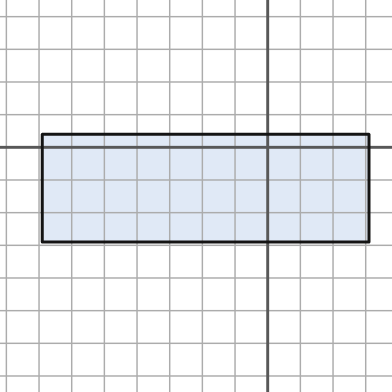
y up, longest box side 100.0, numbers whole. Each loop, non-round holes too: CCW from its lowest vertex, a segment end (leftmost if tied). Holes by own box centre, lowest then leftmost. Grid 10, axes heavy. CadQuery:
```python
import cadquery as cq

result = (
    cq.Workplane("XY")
    .moveTo(-69.0, -29.0)
    .lineTo(31.0, -29.0)
    .lineTo(31.0, 4.0)
    .lineTo(-69.0, 4.0)
    .close()
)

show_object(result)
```